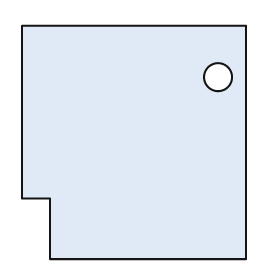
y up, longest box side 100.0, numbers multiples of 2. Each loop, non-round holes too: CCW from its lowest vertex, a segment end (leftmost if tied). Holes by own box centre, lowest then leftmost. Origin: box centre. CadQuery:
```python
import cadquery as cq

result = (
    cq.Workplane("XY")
    .moveTo(-36.0, -50.0)
    .lineTo(48.0, -50.0)
    .lineTo(48.0, 50.0)
    .lineTo(-48.0, 50.0)
    .lineTo(-48.0, -24.0)
    .lineTo(-36.0, -24.0)
    .close()
    .moveTo(36.0, 28.0)
    .circle(6.0)
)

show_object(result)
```